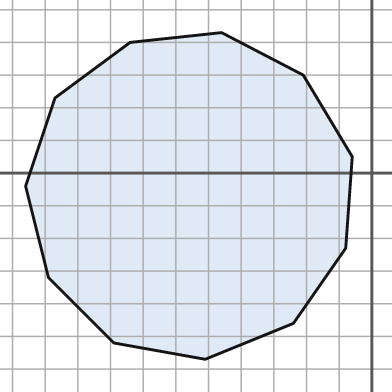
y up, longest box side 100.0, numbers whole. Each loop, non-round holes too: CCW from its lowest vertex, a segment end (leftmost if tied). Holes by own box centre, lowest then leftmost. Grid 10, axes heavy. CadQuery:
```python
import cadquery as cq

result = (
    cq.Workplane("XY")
    .moveTo(-51.0, -57.0)
    .lineTo(-24.0, -46.0)
    .lineTo(-8.0, -23.0)
    .lineTo(-6.0, 5.0)
    .lineTo(-21.0, 30.0)
    .lineTo(-46.0, 43.0)
    .lineTo(-74.0, 40.0)
    .lineTo(-97.0, 23.0)
    .lineTo(-106.0, -4.0)
    .lineTo(-99.0, -32.0)
    .lineTo(-79.0, -52.0)
    .close()
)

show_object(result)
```